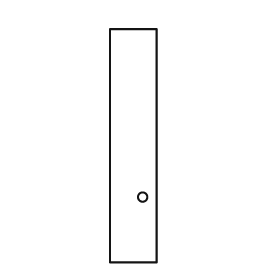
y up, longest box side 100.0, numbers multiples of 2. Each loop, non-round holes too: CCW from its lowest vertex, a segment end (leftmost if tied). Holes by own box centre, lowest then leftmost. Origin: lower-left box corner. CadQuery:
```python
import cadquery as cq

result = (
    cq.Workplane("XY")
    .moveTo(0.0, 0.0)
    .lineTo(20.0, 0.0)
    .lineTo(20.0, 100.0)
    .lineTo(0.0, 100.0)
    .close()
    .moveTo(14.0, 28.0)
    .circle(2.0)
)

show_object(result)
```